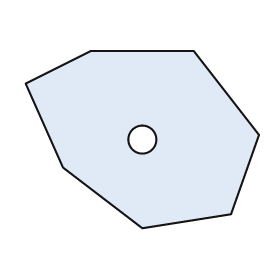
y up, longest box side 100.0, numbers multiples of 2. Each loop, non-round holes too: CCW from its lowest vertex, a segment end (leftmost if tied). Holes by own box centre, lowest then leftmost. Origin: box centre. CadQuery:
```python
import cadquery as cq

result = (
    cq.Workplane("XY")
    .moveTo(0.0, -38.0)
    .lineTo(38.0, -32.0)
    .lineTo(50.0, 2.0)
    .lineTo(22.0, 38.0)
    .lineTo(-22.0, 38.0)
    .lineTo(-50.0, 24.0)
    .lineTo(-34.0, -12.0)
    .close()
    .moveTo(0.0, 0.0)
    .circle(6.0)
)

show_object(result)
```